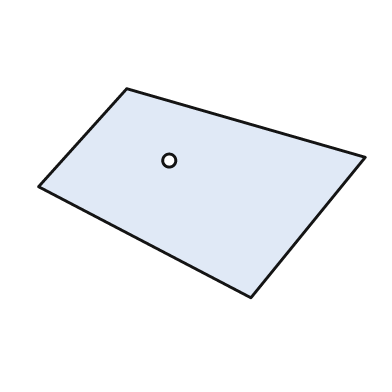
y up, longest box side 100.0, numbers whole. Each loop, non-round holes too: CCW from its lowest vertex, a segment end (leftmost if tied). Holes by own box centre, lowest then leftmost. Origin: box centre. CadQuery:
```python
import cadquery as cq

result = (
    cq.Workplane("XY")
    .moveTo(15.0, -32.0)
    .lineTo(50.0, 11.0)
    .lineTo(-23.0, 32.0)
    .lineTo(-50.0, 2.0)
    .close()
    .moveTo(-10.0, 10.0)
    .circle(2.0)
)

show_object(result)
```